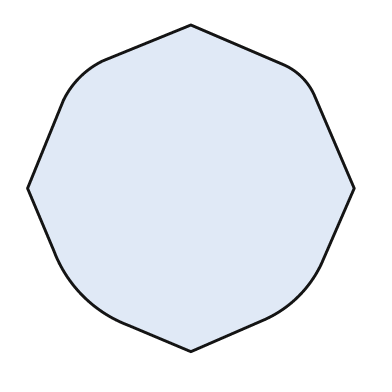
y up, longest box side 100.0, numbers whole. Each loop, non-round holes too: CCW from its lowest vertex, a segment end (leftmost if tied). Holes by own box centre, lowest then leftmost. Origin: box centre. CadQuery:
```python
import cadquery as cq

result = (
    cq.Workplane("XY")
    .moveTo(0.0, -50.0)
    .lineTo(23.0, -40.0)
    .threePointArc((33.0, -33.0), (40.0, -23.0))
    .lineTo(50.0, 0.0)
    .lineTo(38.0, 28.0)
    .threePointArc((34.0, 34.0), (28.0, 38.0))
    .lineTo(0.0, 50.0)
    .lineTo(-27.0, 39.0)
    .threePointArc((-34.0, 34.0), (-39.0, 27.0))
    .lineTo(-50.0, 0.0)
    .lineTo(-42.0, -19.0)
    .threePointArc((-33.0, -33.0), (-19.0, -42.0))
    .close()
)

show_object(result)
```